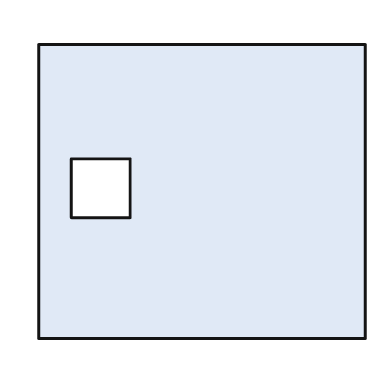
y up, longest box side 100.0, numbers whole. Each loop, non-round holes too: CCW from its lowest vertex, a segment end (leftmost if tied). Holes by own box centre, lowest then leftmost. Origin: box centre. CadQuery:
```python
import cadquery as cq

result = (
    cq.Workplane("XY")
    .moveTo(-50.0, -45.0)
    .lineTo(50.0, -45.0)
    .lineTo(50.0, 45.0)
    .lineTo(-50.0, 45.0)
    .close()
    .moveTo(-40.0, -8.0)
    .lineTo(-22.0, -8.0)
    .lineTo(-22.0, 10.0)
    .lineTo(-40.0, 10.0)
    .close()
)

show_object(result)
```